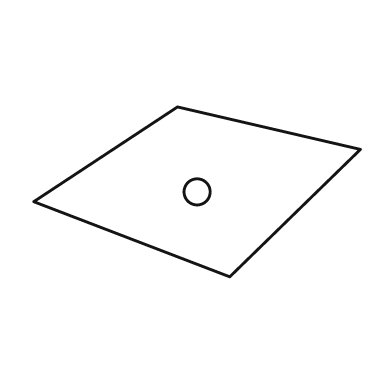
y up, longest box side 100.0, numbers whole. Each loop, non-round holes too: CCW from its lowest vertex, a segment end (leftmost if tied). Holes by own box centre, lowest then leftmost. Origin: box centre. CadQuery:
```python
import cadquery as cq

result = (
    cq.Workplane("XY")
    .moveTo(10.0, -26.0)
    .lineTo(50.0, 13.0)
    .lineTo(-6.0, 26.0)
    .lineTo(-50.0, -3.0)
    .close()
    .moveTo(0.0, 0.0)
    .circle(4.0)
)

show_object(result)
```